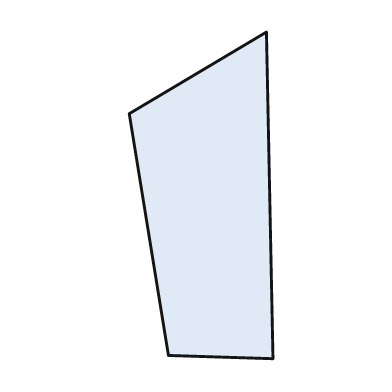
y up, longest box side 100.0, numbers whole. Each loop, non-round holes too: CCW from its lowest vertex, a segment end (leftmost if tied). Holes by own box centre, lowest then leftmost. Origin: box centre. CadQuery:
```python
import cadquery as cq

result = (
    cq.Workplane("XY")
    .moveTo(22.0, -50.0)
    .lineTo(20.0, 50.0)
    .lineTo(-22.0, 25.0)
    .lineTo(-10.0, -49.0)
    .close()
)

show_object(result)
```